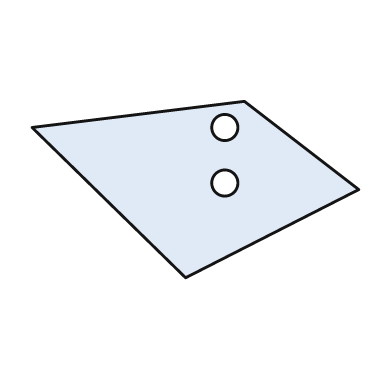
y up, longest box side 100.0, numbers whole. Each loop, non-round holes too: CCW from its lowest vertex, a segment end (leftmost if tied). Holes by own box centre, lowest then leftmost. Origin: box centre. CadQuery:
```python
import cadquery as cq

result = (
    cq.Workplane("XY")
    .moveTo(-3.0, -27.0)
    .lineTo(50.0, 0.0)
    .lineTo(15.0, 27.0)
    .lineTo(-50.0, 19.0)
    .close()
    .moveTo(9.0, 2.0)
    .circle(4.0)
    .moveTo(9.0, 19.0)
    .circle(4.0)
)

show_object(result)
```